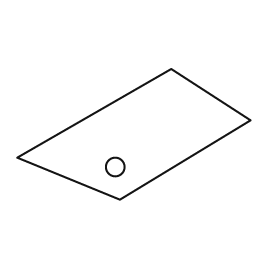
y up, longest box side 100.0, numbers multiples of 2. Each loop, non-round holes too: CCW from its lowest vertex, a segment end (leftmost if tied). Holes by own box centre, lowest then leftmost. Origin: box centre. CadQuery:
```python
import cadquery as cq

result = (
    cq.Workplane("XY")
    .moveTo(-6.0, -28.0)
    .lineTo(50.0, 6.0)
    .lineTo(16.0, 28.0)
    .lineTo(-50.0, -10.0)
    .close()
    .moveTo(-8.0, -14.0)
    .circle(4.0)
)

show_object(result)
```